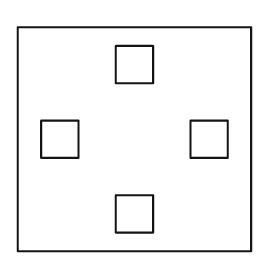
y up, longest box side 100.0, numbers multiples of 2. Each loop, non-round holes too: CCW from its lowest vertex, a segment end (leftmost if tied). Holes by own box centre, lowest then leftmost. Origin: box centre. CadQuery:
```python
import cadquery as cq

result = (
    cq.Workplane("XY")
    .moveTo(-50.0, -48.0)
    .lineTo(50.0, -48.0)
    .lineTo(50.0, 48.0)
    .lineTo(-50.0, 48.0)
    .close()
    .moveTo(-8.0, -40.0)
    .lineTo(8.0, -40.0)
    .lineTo(8.0, -24.0)
    .lineTo(-8.0, -24.0)
    .close()
    .moveTo(-40.0, -8.0)
    .lineTo(-24.0, -8.0)
    .lineTo(-24.0, 8.0)
    .lineTo(-40.0, 8.0)
    .close()
    .moveTo(24.0, -8.0)
    .lineTo(40.0, -8.0)
    .lineTo(40.0, 8.0)
    .lineTo(24.0, 8.0)
    .close()
    .moveTo(-8.0, 24.0)
    .lineTo(8.0, 24.0)
    .lineTo(8.0, 40.0)
    .lineTo(-8.0, 40.0)
    .close()
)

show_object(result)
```